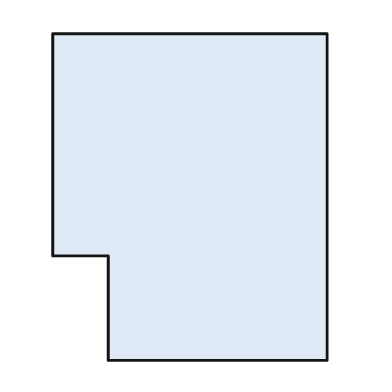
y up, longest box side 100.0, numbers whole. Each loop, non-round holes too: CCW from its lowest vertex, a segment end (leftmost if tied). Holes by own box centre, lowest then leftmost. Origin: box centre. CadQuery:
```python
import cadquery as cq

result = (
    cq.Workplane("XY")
    .moveTo(-25.0, -50.0)
    .lineTo(42.0, -50.0)
    .lineTo(42.0, 50.0)
    .lineTo(-42.0, 50.0)
    .lineTo(-42.0, -18.0)
    .lineTo(-25.0, -18.0)
    .close()
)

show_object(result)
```